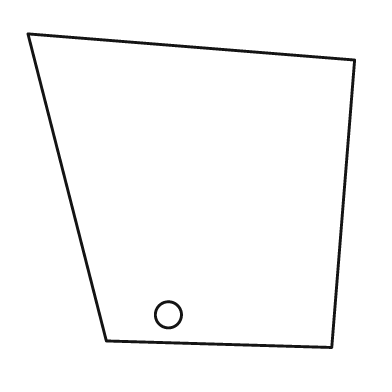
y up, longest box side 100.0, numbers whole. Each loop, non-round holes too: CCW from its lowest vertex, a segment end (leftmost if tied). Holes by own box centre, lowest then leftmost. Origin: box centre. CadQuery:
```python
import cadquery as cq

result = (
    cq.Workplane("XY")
    .moveTo(43.0, -48.0)
    .lineTo(50.0, 40.0)
    .lineTo(-50.0, 48.0)
    .lineTo(-26.0, -46.0)
    .close()
    .moveTo(-7.0, -38.0)
    .circle(4.0)
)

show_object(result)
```